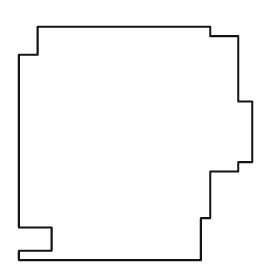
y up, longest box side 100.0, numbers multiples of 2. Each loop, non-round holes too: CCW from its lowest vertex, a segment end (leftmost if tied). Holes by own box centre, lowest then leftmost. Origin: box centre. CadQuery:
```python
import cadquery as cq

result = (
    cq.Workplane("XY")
    .moveTo(-50.0, -50.0)
    .lineTo(28.0, -50.0)
    .lineTo(28.0, -32.0)
    .lineTo(32.0, -32.0)
    .lineTo(32.0, -12.0)
    .lineTo(44.0, -12.0)
    .lineTo(44.0, -8.0)
    .lineTo(50.0, -8.0)
    .lineTo(50.0, 18.0)
    .lineTo(44.0, 18.0)
    .lineTo(44.0, 46.0)
    .lineTo(32.0, 46.0)
    .lineTo(32.0, 50.0)
    .lineTo(-42.0, 50.0)
    .lineTo(-42.0, 38.0)
    .lineTo(-50.0, 38.0)
    .lineTo(-50.0, -36.0)
    .lineTo(-36.0, -36.0)
    .lineTo(-36.0, -46.0)
    .lineTo(-50.0, -46.0)
    .close()
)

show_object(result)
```